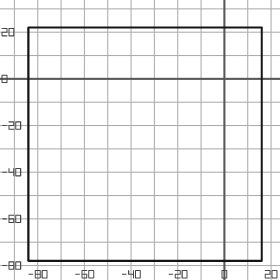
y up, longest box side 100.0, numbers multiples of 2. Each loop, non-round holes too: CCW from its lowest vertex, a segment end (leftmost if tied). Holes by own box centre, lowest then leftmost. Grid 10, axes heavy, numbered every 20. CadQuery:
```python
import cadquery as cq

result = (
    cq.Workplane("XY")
    .moveTo(-84.0, -78.0)
    .lineTo(16.0, -78.0)
    .lineTo(16.0, 22.0)
    .lineTo(-84.0, 22.0)
    .close()
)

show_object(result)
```